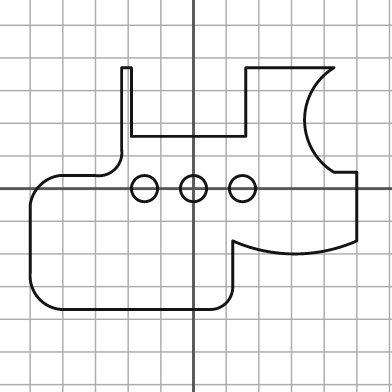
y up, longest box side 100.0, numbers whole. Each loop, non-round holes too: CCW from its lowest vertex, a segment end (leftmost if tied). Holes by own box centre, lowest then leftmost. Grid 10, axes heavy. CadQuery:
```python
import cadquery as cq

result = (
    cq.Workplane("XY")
    .moveTo(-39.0, -37.0)
    .lineTo(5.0, -37.0)
    .threePointArc((10.0, -35.0), (12.0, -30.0))
    .lineTo(12.0, -16.0)
    .threePointArc((31.0, -20.0), (50.0, -16.0))
    .lineTo(50.0, 5.0)
    .lineTo(43.0, 5.0)
    .threePointArc((34.0, 21.0), (43.0, 37.0))
    .lineTo(16.0, 37.0)
    .lineTo(16.0, 16.0)
    .lineTo(-19.0, 16.0)
    .lineTo(-19.0, 37.0)
    .lineTo(-22.0, 37.0)
    .lineTo(-22.0, 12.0)
    .threePointArc((-24.0, 6.0), (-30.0, 4.0))
    .lineTo(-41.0, 4.0)
    .threePointArc((-47.0, 1.0), (-50.0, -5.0))
    .lineTo(-50.0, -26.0)
    .threePointArc((-47.0, -34.0), (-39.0, -37.0))
    .close()
    .moveTo(-15.0, 0.0)
    .circle(4.0)
    .moveTo(0.0, 0.0)
    .circle(4.0)
    .moveTo(15.0, 0.0)
    .circle(4.0)
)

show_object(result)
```